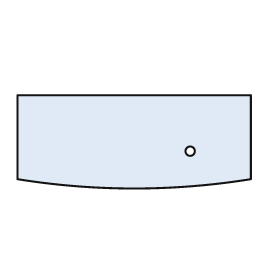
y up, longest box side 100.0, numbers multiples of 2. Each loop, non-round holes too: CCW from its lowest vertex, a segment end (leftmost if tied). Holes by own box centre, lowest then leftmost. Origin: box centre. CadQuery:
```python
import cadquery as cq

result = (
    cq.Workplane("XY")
    .moveTo(-50.0, -16.0)
    .threePointArc((0.0, -20.0), (50.0, -16.0))
    .lineTo(50.0, 20.0)
    .lineTo(-50.0, 20.0)
    .close()
    .moveTo(24.0, -4.0)
    .circle(2.0)
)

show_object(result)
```